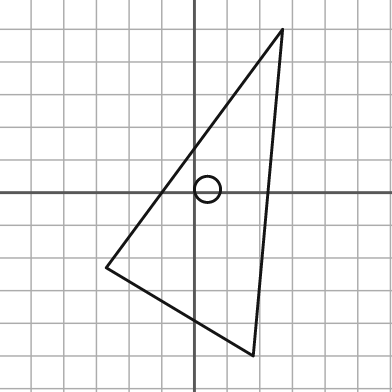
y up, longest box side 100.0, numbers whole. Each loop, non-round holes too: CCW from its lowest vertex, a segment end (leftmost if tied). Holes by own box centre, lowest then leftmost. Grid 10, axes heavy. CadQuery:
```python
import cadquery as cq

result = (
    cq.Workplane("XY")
    .moveTo(18.0, -50.0)
    .lineTo(27.0, 50.0)
    .lineTo(-27.0, -23.0)
    .close()
    .moveTo(4.0, 1.0)
    .circle(4.0)
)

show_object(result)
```